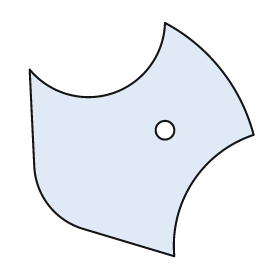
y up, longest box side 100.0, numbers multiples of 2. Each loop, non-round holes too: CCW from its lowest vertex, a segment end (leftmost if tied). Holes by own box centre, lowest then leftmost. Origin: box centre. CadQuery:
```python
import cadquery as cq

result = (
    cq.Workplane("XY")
    .moveTo(14.0, -50.0)
    .threePointArc((22.0, -18.0), (48.0, 2.0))
    .threePointArc((34.0, 30.0), (10.0, 50.0))
    .threePointArc((-12.0, 20.0), (-48.0, 30.0))
    .lineTo(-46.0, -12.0)
    .threePointArc((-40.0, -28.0), (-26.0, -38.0))
    .close()
    .moveTo(10.0, 4.0)
    .circle(4.0)
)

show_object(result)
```